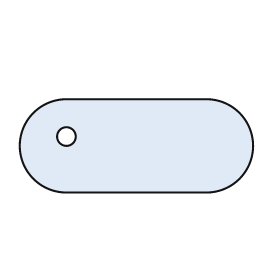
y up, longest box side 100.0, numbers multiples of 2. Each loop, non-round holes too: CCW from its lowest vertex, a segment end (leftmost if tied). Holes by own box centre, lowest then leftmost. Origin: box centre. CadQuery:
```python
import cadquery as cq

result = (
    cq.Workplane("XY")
    .moveTo(-30.0, -20.0)
    .lineTo(30.0, -20.0)
    .threePointArc((50.0, 0.0), (30.0, 20.0))
    .lineTo(-30.0, 20.0)
    .threePointArc((-50.0, 0.0), (-30.0, -20.0))
    .close()
    .moveTo(-30.0, 4.0)
    .circle(4.0)
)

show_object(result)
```